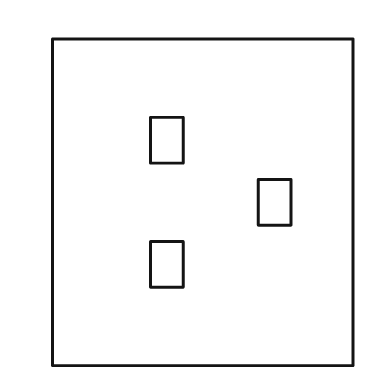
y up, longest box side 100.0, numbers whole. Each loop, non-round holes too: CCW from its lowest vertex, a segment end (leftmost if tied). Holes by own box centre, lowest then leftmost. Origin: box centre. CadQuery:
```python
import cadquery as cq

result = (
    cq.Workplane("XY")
    .moveTo(-46.0, -50.0)
    .lineTo(46.0, -50.0)
    .lineTo(46.0, 50.0)
    .lineTo(-46.0, 50.0)
    .close()
    .moveTo(-16.0, -26.0)
    .lineTo(-6.0, -26.0)
    .lineTo(-6.0, -12.0)
    .lineTo(-16.0, -12.0)
    .close()
    .moveTo(17.0, -7.0)
    .lineTo(27.0, -7.0)
    .lineTo(27.0, 7.0)
    .lineTo(17.0, 7.0)
    .close()
    .moveTo(-16.0, 12.0)
    .lineTo(-6.0, 12.0)
    .lineTo(-6.0, 26.0)
    .lineTo(-16.0, 26.0)
    .close()
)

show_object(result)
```